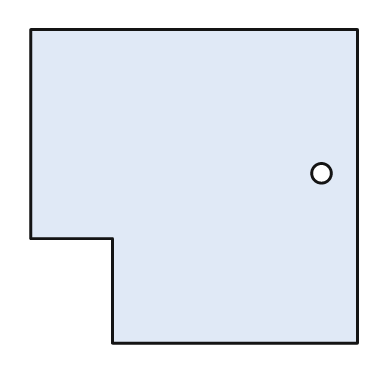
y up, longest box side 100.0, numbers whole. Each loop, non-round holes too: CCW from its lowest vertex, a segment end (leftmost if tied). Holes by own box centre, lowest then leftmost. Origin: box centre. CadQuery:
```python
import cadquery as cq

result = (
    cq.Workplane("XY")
    .moveTo(-25.0, -48.0)
    .lineTo(50.0, -48.0)
    .lineTo(50.0, 48.0)
    .lineTo(-50.0, 48.0)
    .lineTo(-50.0, -16.0)
    .lineTo(-25.0, -16.0)
    .close()
    .moveTo(39.0, 4.0)
    .circle(3.0)
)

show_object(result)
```